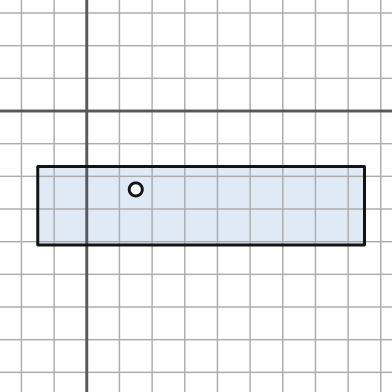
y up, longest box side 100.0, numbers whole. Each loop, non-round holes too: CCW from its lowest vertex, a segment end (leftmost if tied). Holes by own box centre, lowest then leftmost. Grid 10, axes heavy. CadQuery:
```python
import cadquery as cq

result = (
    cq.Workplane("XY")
    .moveTo(-15.0, -41.0)
    .lineTo(85.0, -41.0)
    .lineTo(85.0, -17.0)
    .lineTo(-15.0, -17.0)
    .close()
    .moveTo(15.0, -24.0)
    .circle(2.0)
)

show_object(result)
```